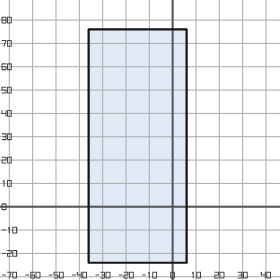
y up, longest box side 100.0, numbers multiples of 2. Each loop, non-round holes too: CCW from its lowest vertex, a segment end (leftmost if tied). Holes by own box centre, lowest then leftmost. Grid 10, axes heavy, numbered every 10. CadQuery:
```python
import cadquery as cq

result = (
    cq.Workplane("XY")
    .moveTo(-36.0, -24.0)
    .lineTo(6.0, -24.0)
    .lineTo(6.0, 76.0)
    .lineTo(-36.0, 76.0)
    .close()
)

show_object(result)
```